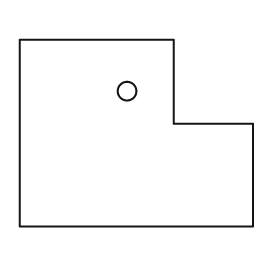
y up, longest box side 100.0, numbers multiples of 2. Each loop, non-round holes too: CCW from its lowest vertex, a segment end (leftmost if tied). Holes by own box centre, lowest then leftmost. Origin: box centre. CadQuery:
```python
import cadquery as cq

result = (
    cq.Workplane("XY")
    .moveTo(-50.0, -40.0)
    .lineTo(50.0, -40.0)
    .lineTo(50.0, 4.0)
    .lineTo(16.0, 4.0)
    .lineTo(16.0, 40.0)
    .lineTo(-50.0, 40.0)
    .close()
    .moveTo(-4.0, 18.0)
    .circle(4.0)
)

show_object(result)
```